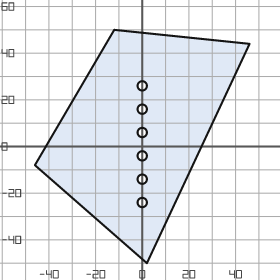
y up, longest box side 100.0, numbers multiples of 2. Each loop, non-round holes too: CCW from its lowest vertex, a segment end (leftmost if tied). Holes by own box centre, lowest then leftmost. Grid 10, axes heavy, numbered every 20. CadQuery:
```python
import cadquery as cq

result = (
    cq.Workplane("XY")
    .moveTo(2.0, -50.0)
    .lineTo(46.0, 44.0)
    .lineTo(-12.0, 50.0)
    .lineTo(-46.0, -8.0)
    .close()
    .moveTo(0.0, -24.0)
    .circle(2.0)
    .moveTo(0.0, -14.0)
    .circle(2.0)
    .moveTo(0.0, -4.0)
    .circle(2.0)
    .moveTo(0.0, 6.0)
    .circle(2.0)
    .moveTo(0.0, 16.0)
    .circle(2.0)
    .moveTo(0.0, 26.0)
    .circle(2.0)
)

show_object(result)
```